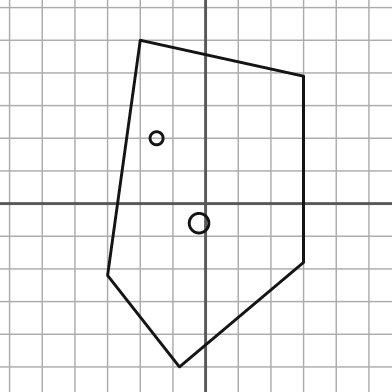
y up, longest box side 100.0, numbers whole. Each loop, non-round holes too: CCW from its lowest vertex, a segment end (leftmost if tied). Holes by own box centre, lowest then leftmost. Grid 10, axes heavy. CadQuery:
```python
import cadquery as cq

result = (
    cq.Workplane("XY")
    .moveTo(-8.0, -50.0)
    .lineTo(30.0, -18.0)
    .lineTo(30.0, 39.0)
    .lineTo(-20.0, 50.0)
    .lineTo(-30.0, -22.0)
    .close()
    .moveTo(-2.0, -6.0)
    .circle(3.0)
    .moveTo(-15.0, 20.0)
    .circle(2.0)
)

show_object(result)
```